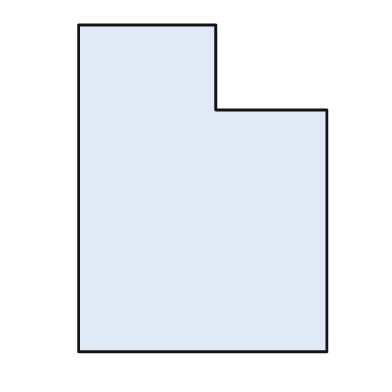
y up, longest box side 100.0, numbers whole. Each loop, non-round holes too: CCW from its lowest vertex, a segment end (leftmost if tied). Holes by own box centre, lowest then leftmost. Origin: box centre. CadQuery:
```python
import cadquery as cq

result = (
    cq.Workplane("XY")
    .moveTo(-38.0, -50.0)
    .lineTo(38.0, -50.0)
    .lineTo(38.0, 24.0)
    .lineTo(4.0, 24.0)
    .lineTo(4.0, 50.0)
    .lineTo(-38.0, 50.0)
    .close()
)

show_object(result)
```